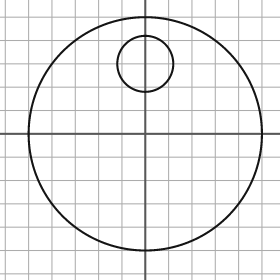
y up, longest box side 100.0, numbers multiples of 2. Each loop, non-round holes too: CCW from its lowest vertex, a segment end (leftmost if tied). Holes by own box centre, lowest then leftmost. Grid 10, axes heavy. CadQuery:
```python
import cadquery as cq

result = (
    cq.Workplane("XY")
    .moveTo(0.0, 0.0)
    .circle(50.0)
    .moveTo(0.0, 30.0)
    .circle(12.0)
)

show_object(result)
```